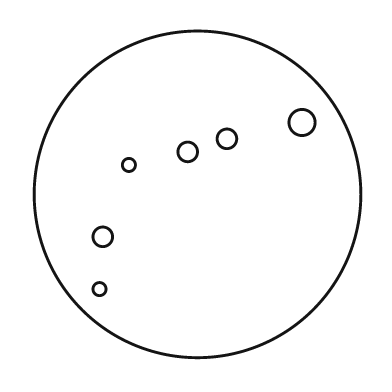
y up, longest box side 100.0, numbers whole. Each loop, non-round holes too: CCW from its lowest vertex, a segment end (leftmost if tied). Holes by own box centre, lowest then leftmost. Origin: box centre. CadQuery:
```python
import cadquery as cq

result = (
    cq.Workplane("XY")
    .moveTo(0.0, 0.0)
    .circle(50.0)
    .moveTo(-30.0, -29.0)
    .circle(2.0)
    .moveTo(-29.0, -13.0)
    .circle(3.0)
    .moveTo(-21.0, 9.0)
    .circle(2.0)
    .moveTo(-3.0, 13.0)
    .circle(3.0)
    .moveTo(9.0, 17.0)
    .circle(3.0)
    .moveTo(32.0, 22.0)
    .circle(4.0)
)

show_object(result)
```